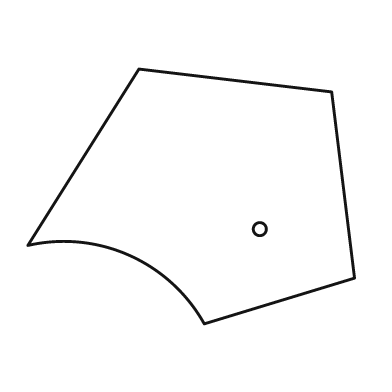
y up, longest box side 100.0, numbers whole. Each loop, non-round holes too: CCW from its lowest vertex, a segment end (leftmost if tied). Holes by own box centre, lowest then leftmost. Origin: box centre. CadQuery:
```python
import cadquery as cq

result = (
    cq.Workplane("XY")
    .moveTo(4.0, -39.0)
    .lineTo(50.0, -25.0)
    .lineTo(43.0, 32.0)
    .lineTo(-16.0, 39.0)
    .lineTo(-50.0, -15.0)
    .threePointArc((-19.0, -18.0), (4.0, -39.0))
    .close()
    .moveTo(21.0, -10.0)
    .circle(2.0)
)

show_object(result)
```